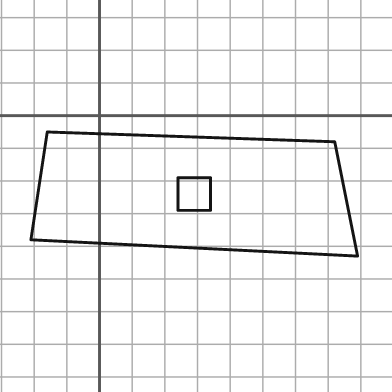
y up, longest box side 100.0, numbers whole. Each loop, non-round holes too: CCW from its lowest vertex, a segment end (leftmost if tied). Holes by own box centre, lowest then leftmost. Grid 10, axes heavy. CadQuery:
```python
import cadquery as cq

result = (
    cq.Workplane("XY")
    .moveTo(79.0, -43.0)
    .lineTo(72.0, -8.0)
    .lineTo(-16.0, -5.0)
    .lineTo(-21.0, -38.0)
    .close()
    .moveTo(24.0, -29.0)
    .lineTo(34.0, -29.0)
    .lineTo(34.0, -19.0)
    .lineTo(24.0, -19.0)
    .close()
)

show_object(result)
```